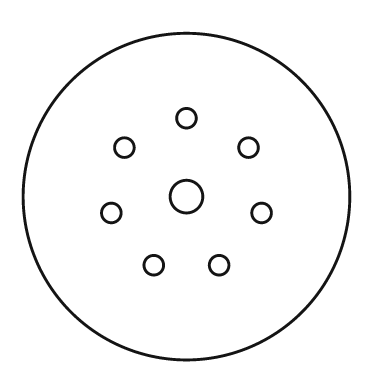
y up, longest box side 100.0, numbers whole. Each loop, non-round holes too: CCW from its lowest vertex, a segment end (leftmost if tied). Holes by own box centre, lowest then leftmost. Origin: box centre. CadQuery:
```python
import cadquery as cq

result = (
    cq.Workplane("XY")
    .moveTo(0.0, 0.0)
    .circle(50.0)
    .moveTo(-10.0, -21.0)
    .circle(3.0)
    .moveTo(10.0, -21.0)
    .circle(3.0)
    .moveTo(-23.0, -5.0)
    .circle(3.0)
    .moveTo(23.0, -5.0)
    .circle(3.0)
    .moveTo(0.0, 0.0)
    .circle(5.0)
    .moveTo(-19.0, 15.0)
    .circle(3.0)
    .moveTo(19.0, 15.0)
    .circle(3.0)
    .moveTo(0.0, 24.0)
    .circle(3.0)
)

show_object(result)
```